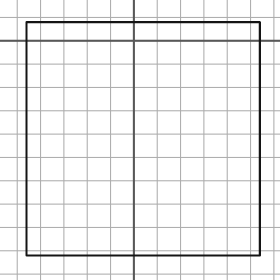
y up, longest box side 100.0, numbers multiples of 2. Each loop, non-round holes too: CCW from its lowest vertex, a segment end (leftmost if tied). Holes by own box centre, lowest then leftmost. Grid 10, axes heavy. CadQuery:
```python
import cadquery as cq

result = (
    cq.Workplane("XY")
    .moveTo(-46.0, -92.0)
    .lineTo(54.0, -92.0)
    .lineTo(54.0, 8.0)
    .lineTo(-46.0, 8.0)
    .close()
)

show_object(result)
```